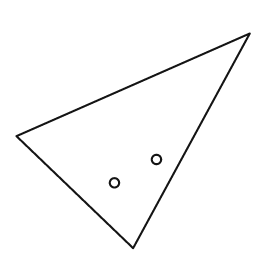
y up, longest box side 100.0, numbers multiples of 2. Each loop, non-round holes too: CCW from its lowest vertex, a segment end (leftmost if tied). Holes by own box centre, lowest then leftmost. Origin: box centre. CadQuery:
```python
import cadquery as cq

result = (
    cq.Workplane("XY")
    .moveTo(0.0, -46.0)
    .lineTo(50.0, 46.0)
    .lineTo(-50.0, 2.0)
    .close()
    .moveTo(-8.0, -18.0)
    .circle(2.0)
    .moveTo(10.0, -8.0)
    .circle(2.0)
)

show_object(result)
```